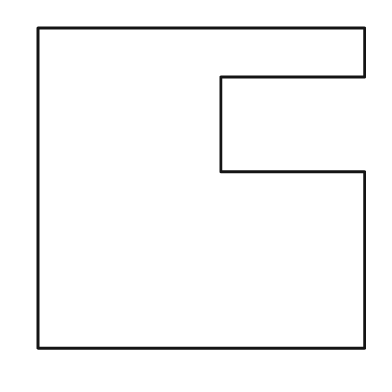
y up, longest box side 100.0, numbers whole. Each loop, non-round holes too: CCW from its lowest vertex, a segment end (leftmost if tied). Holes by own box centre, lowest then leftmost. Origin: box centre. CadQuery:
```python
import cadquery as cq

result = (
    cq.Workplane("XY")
    .moveTo(-50.0, -49.0)
    .lineTo(50.0, -49.0)
    .lineTo(50.0, 5.0)
    .lineTo(6.0, 5.0)
    .lineTo(6.0, 34.0)
    .lineTo(50.0, 34.0)
    .lineTo(50.0, 49.0)
    .lineTo(-50.0, 49.0)
    .close()
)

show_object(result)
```